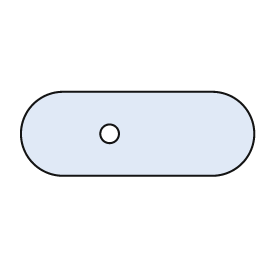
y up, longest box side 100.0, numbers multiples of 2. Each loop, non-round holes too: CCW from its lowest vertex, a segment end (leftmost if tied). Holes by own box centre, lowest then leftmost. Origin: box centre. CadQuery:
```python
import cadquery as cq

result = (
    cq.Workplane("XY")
    .moveTo(-32.0, -18.0)
    .lineTo(32.0, -18.0)
    .threePointArc((50.0, 0.0), (32.0, 18.0))
    .lineTo(-32.0, 18.0)
    .threePointArc((-50.0, 0.0), (-32.0, -18.0))
    .close()
    .moveTo(-12.0, 0.0)
    .circle(4.0)
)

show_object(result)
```